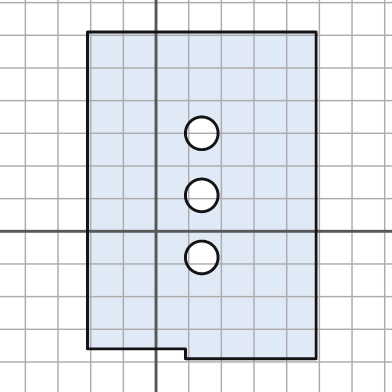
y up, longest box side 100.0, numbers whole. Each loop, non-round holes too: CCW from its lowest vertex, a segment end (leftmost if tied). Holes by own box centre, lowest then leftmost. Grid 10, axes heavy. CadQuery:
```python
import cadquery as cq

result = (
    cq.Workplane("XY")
    .moveTo(9.0, -39.0)
    .lineTo(49.0, -39.0)
    .lineTo(49.0, 61.0)
    .lineTo(-21.0, 61.0)
    .lineTo(-21.0, -36.0)
    .lineTo(9.0, -36.0)
    .close()
    .moveTo(14.0, -8.0)
    .circle(5.0)
    .moveTo(14.0, 11.0)
    .circle(5.0)
    .moveTo(14.0, 30.0)
    .circle(5.0)
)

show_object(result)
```